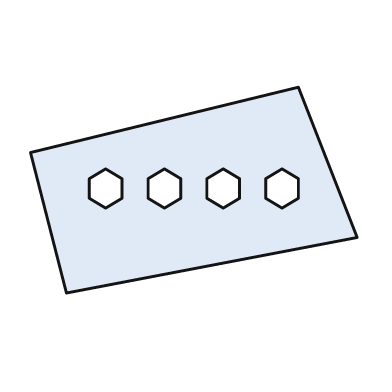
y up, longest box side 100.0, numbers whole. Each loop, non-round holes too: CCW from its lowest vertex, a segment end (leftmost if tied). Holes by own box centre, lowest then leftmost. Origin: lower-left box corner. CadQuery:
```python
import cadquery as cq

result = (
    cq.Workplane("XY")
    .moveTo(11.0, 0.0)
    .lineTo(100.0, 17.0)
    .lineTo(82.0, 63.0)
    .lineTo(0.0, 43.0)
    .close()
    .moveTo(23.0, 26.0)
    .lineTo(28.0, 29.0)
    .lineTo(28.0, 35.0)
    .lineTo(23.0, 38.0)
    .lineTo(18.0, 35.0)
    .lineTo(18.0, 29.0)
    .close()
    .moveTo(41.0, 26.0)
    .lineTo(46.0, 29.0)
    .lineTo(46.0, 35.0)
    .lineTo(41.0, 38.0)
    .lineTo(36.0, 35.0)
    .lineTo(36.0, 29.0)
    .close()
    .moveTo(59.0, 26.0)
    .lineTo(64.0, 29.0)
    .lineTo(64.0, 35.0)
    .lineTo(59.0, 38.0)
    .lineTo(54.0, 35.0)
    .lineTo(54.0, 29.0)
    .close()
    .moveTo(77.0, 26.0)
    .lineTo(82.0, 29.0)
    .lineTo(82.0, 35.0)
    .lineTo(77.0, 38.0)
    .lineTo(72.0, 35.0)
    .lineTo(72.0, 29.0)
    .close()
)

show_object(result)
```